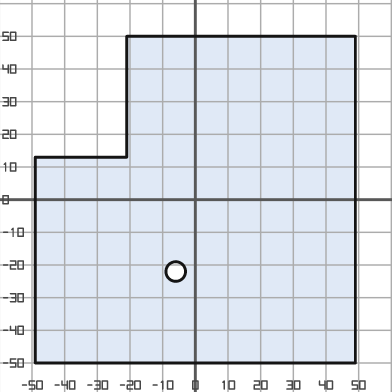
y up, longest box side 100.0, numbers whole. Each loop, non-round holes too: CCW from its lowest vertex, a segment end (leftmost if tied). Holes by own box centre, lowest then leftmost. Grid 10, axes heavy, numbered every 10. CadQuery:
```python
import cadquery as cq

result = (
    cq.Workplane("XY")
    .moveTo(-49.0, -50.0)
    .lineTo(49.0, -50.0)
    .lineTo(49.0, 50.0)
    .lineTo(-21.0, 50.0)
    .lineTo(-21.0, 13.0)
    .lineTo(-49.0, 13.0)
    .close()
    .moveTo(-6.0, -22.0)
    .circle(3.0)
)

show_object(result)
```